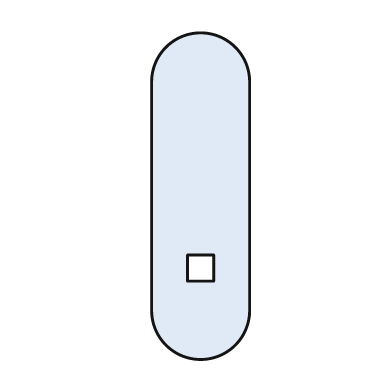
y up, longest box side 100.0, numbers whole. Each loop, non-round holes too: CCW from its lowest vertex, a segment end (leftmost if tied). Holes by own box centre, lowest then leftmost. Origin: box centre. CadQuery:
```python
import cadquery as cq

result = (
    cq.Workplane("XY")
    .moveTo(-15.0, -35.0)
    .threePointArc((0.0, -50.0), (15.0, -35.0))
    .lineTo(15.0, 35.0)
    .threePointArc((0.0, 50.0), (-15.0, 35.0))
    .close()
    .moveTo(-4.0, -26.0)
    .lineTo(4.0, -26.0)
    .lineTo(4.0, -18.0)
    .lineTo(-4.0, -18.0)
    .close()
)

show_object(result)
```